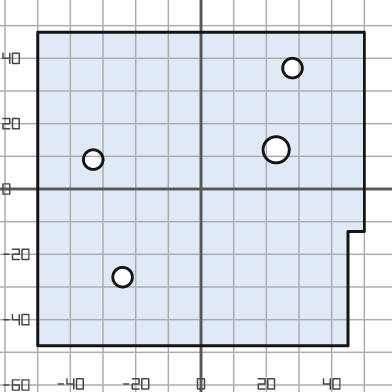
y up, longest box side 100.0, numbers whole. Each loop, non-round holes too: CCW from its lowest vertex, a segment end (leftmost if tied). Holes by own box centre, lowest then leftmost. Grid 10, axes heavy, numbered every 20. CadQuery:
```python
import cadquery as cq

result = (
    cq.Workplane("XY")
    .moveTo(-50.0, -48.0)
    .lineTo(45.0, -48.0)
    .lineTo(45.0, -13.0)
    .lineTo(50.0, -13.0)
    .lineTo(50.0, 48.0)
    .lineTo(-50.0, 48.0)
    .close()
    .moveTo(-24.0, -27.0)
    .circle(3.0)
    .moveTo(-33.0, 9.0)
    .circle(3.0)
    .moveTo(23.0, 12.0)
    .circle(4.0)
    .moveTo(28.0, 37.0)
    .circle(3.0)
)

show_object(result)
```